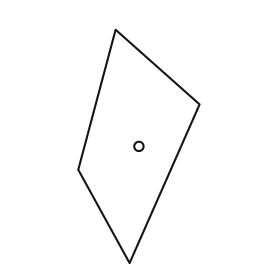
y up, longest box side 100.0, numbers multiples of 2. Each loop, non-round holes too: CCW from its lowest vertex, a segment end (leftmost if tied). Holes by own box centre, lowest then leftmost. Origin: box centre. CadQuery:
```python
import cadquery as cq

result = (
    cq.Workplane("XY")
    .moveTo(-4.0, -50.0)
    .lineTo(26.0, 18.0)
    .lineTo(-10.0, 50.0)
    .lineTo(-26.0, -10.0)
    .close()
    .moveTo(0.0, 0.0)
    .circle(2.0)
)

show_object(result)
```